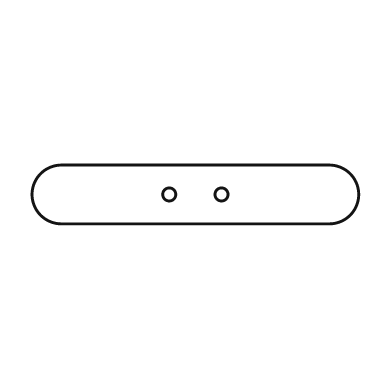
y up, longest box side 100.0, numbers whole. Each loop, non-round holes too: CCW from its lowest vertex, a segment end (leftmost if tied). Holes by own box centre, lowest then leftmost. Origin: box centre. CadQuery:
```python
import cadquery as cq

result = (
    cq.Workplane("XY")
    .moveTo(-41.0, -9.0)
    .lineTo(41.0, -9.0)
    .threePointArc((50.0, 0.0), (41.0, 9.0))
    .lineTo(-41.0, 9.0)
    .threePointArc((-50.0, 0.0), (-41.0, -9.0))
    .close()
    .moveTo(-8.0, 0.0)
    .circle(2.0)
    .moveTo(8.0, 0.0)
    .circle(2.0)
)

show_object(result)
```